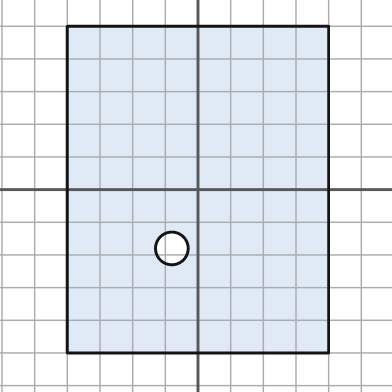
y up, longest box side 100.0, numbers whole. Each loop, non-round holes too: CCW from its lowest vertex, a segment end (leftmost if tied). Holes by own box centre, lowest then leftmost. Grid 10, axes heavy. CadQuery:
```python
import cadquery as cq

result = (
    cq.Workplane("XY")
    .moveTo(-40.0, -50.0)
    .lineTo(40.0, -50.0)
    .lineTo(40.0, 50.0)
    .lineTo(-40.0, 50.0)
    .close()
    .moveTo(-8.0, -18.0)
    .circle(5.0)
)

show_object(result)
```